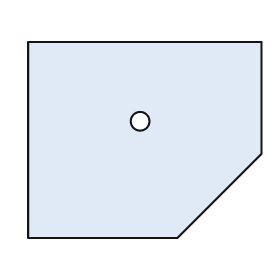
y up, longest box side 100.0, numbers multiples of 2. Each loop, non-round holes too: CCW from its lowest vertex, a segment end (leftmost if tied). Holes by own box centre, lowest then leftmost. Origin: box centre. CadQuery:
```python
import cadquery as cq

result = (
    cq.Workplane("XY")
    .moveTo(-50.0, -42.0)
    .lineTo(14.0, -42.0)
    .lineTo(50.0, -6.0)
    .lineTo(50.0, 42.0)
    .lineTo(-50.0, 42.0)
    .close()
    .moveTo(-2.0, 8.0)
    .circle(4.0)
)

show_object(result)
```